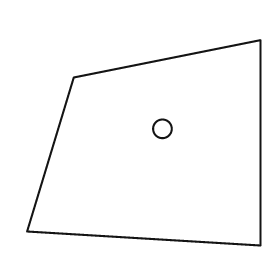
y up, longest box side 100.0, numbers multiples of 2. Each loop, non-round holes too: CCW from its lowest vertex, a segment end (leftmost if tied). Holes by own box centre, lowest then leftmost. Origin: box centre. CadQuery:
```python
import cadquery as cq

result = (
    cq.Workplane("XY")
    .moveTo(50.0, -44.0)
    .lineTo(50.0, 44.0)
    .lineTo(-30.0, 28.0)
    .lineTo(-50.0, -38.0)
    .close()
    .moveTo(8.0, 6.0)
    .circle(4.0)
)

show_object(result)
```